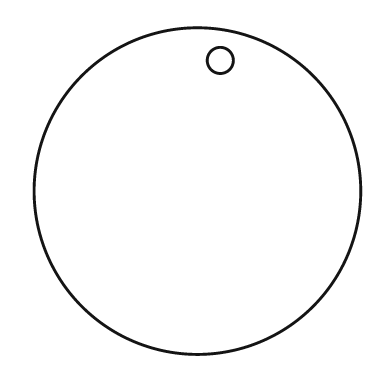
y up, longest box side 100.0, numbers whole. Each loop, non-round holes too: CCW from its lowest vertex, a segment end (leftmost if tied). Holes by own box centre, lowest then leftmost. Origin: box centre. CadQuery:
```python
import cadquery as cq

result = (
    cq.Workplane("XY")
    .moveTo(0.0, 0.0)
    .circle(50.0)
    .moveTo(7.0, 40.0)
    .circle(4.0)
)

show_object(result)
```